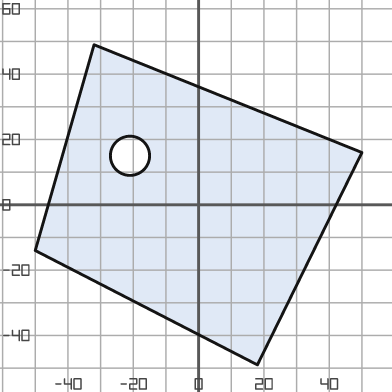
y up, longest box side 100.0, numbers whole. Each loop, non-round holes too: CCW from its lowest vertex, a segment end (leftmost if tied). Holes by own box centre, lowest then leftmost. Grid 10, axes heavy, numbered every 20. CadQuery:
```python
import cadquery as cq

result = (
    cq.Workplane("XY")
    .moveTo(18.0, -49.0)
    .lineTo(50.0, 16.0)
    .lineTo(-32.0, 49.0)
    .lineTo(-50.0, -14.0)
    .close()
    .moveTo(-21.0, 15.0)
    .circle(6.0)
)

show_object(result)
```